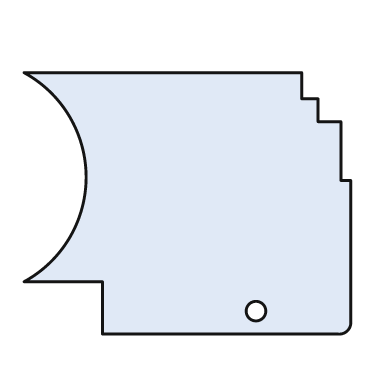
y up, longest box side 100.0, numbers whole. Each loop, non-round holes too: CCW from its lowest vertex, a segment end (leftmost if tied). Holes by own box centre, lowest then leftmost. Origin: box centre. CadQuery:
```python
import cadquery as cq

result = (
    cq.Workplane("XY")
    .moveTo(-26.0, -40.0)
    .lineTo(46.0, -40.0)
    .threePointArc((49.0, -39.0), (50.0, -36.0))
    .lineTo(50.0, 7.0)
    .lineTo(47.0, 7.0)
    .lineTo(47.0, 25.0)
    .lineTo(40.0, 25.0)
    .lineTo(40.0, 32.0)
    .lineTo(35.0, 32.0)
    .lineTo(35.0, 40.0)
    .lineTo(-50.0, 40.0)
    .threePointArc((-31.0, 8.0), (-50.0, -24.0))
    .lineTo(-26.0, -24.0)
    .close()
    .moveTo(21.0, -33.0)
    .circle(3.0)
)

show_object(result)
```